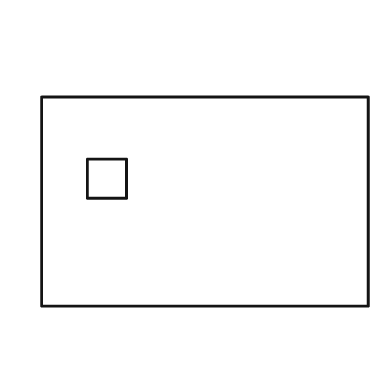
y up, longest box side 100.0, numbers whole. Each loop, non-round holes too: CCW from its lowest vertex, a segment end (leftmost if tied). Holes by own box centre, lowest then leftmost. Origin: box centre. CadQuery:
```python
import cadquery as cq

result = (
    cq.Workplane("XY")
    .moveTo(-50.0, -32.0)
    .lineTo(50.0, -32.0)
    .lineTo(50.0, 32.0)
    .lineTo(-50.0, 32.0)
    .close()
    .moveTo(-36.0, 1.0)
    .lineTo(-24.0, 1.0)
    .lineTo(-24.0, 13.0)
    .lineTo(-36.0, 13.0)
    .close()
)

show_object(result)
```